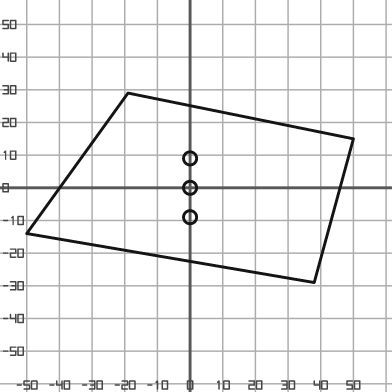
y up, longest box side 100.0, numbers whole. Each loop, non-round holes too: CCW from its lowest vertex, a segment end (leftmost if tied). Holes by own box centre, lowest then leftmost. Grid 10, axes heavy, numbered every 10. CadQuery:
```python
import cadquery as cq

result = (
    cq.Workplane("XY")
    .moveTo(38.0, -29.0)
    .lineTo(50.0, 15.0)
    .lineTo(-19.0, 29.0)
    .lineTo(-50.0, -14.0)
    .close()
    .moveTo(0.0, -9.0)
    .circle(2.0)
    .moveTo(0.0, 0.0)
    .circle(2.0)
    .moveTo(0.0, 9.0)
    .circle(2.0)
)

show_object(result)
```